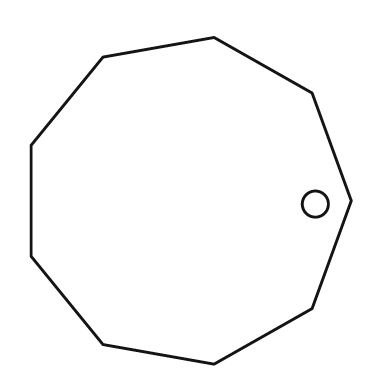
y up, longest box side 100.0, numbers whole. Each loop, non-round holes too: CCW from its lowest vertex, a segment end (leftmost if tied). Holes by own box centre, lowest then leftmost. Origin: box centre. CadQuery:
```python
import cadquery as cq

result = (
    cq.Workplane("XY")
    .moveTo(7.0, -50.0)
    .lineTo(37.0, -33.0)
    .lineTo(49.0, 0.0)
    .lineTo(37.0, 33.0)
    .lineTo(7.0, 50.0)
    .lineTo(-27.0, 44.0)
    .lineTo(-49.0, 17.0)
    .lineTo(-49.0, -17.0)
    .lineTo(-27.0, -44.0)
    .close()
    .moveTo(38.0, -1.0)
    .circle(4.0)
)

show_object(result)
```